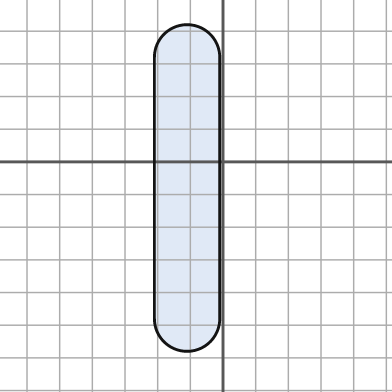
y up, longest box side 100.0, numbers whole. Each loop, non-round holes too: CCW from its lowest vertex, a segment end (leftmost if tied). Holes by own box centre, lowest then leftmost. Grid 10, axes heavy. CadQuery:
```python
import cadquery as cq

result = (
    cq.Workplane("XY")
    .moveTo(-21.0, -48.0)
    .threePointArc((-11.0, -58.0), (-1.0, -48.0))
    .lineTo(-1.0, 32.0)
    .threePointArc((-11.0, 42.0), (-21.0, 32.0))
    .close()
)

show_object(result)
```